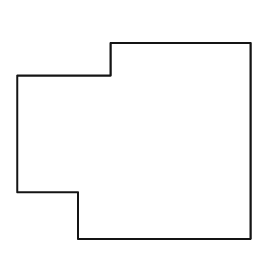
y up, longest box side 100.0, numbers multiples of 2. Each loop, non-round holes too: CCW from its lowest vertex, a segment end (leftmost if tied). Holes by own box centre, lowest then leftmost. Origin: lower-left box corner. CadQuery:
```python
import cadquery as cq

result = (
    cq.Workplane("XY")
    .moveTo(26.0, 0.0)
    .lineTo(100.0, 0.0)
    .lineTo(100.0, 84.0)
    .lineTo(40.0, 84.0)
    .lineTo(40.0, 70.0)
    .lineTo(0.0, 70.0)
    .lineTo(0.0, 20.0)
    .lineTo(26.0, 20.0)
    .close()
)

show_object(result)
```